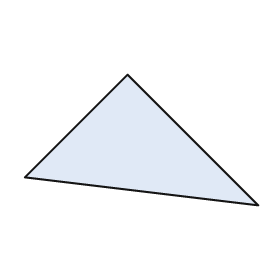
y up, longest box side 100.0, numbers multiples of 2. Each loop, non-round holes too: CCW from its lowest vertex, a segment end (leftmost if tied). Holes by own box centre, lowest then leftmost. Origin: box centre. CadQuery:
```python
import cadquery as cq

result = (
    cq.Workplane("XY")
    .moveTo(50.0, -28.0)
    .lineTo(-6.0, 28.0)
    .lineTo(-50.0, -16.0)
    .close()
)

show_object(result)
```